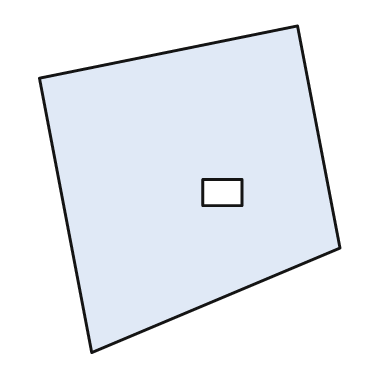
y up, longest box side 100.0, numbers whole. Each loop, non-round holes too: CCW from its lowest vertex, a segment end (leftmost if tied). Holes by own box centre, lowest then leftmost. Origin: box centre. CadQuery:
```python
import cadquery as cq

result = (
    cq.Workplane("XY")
    .moveTo(-30.0, -50.0)
    .lineTo(46.0, -18.0)
    .lineTo(33.0, 50.0)
    .lineTo(-46.0, 34.0)
    .close()
    .moveTo(4.0, -5.0)
    .lineTo(16.0, -5.0)
    .lineTo(16.0, 3.0)
    .lineTo(4.0, 3.0)
    .close()
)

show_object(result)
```